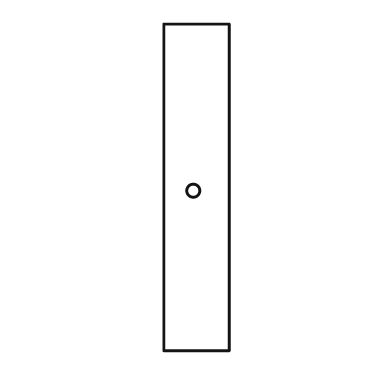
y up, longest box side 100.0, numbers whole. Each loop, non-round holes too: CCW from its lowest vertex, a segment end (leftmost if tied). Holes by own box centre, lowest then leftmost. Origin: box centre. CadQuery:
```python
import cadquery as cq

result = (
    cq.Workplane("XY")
    .moveTo(-10.0, -50.0)
    .lineTo(10.0, -50.0)
    .lineTo(10.0, 50.0)
    .lineTo(-10.0, 50.0)
    .close()
    .moveTo(-1.0, -1.0)
    .circle(2.0)
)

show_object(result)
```